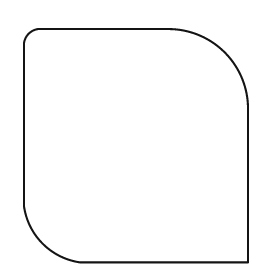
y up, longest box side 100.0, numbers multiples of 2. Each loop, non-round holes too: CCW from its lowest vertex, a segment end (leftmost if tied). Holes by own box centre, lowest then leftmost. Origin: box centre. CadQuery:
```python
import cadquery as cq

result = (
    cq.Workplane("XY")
    .moveTo(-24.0, -50.0)
    .lineTo(48.0, -50.0)
    .lineTo(48.0, 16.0)
    .threePointArc((38.0, 40.0), (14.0, 50.0))
    .lineTo(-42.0, 50.0)
    .threePointArc((-46.0, 48.0), (-48.0, 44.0))
    .lineTo(-48.0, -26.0)
    .threePointArc((-40.0, -42.0), (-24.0, -50.0))
    .close()
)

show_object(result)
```